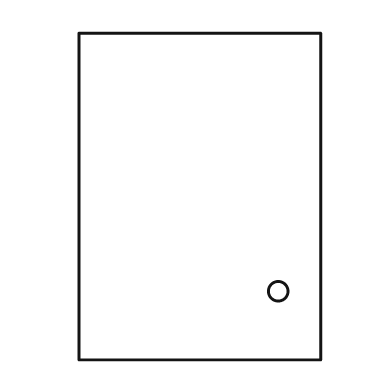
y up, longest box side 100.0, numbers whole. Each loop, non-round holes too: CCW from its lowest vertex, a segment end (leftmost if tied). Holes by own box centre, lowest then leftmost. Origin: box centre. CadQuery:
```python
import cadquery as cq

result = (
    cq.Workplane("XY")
    .moveTo(-37.0, -50.0)
    .lineTo(37.0, -50.0)
    .lineTo(37.0, 50.0)
    .lineTo(-37.0, 50.0)
    .close()
    .moveTo(24.0, -29.0)
    .circle(3.0)
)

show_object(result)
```